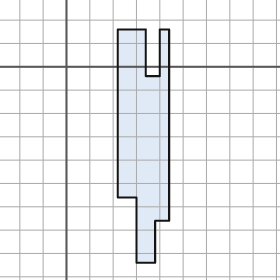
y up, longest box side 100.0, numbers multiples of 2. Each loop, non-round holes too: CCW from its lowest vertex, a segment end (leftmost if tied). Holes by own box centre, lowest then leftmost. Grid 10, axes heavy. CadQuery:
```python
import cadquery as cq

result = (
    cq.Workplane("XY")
    .moveTo(30.0, -84.0)
    .lineTo(38.0, -84.0)
    .lineTo(38.0, -66.0)
    .lineTo(44.0, -66.0)
    .lineTo(44.0, 16.0)
    .lineTo(40.0, 16.0)
    .lineTo(40.0, -4.0)
    .lineTo(34.0, -4.0)
    .lineTo(34.0, 16.0)
    .lineTo(22.0, 16.0)
    .lineTo(22.0, -56.0)
    .lineTo(30.0, -56.0)
    .close()
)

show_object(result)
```